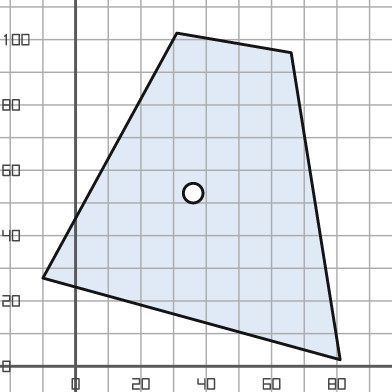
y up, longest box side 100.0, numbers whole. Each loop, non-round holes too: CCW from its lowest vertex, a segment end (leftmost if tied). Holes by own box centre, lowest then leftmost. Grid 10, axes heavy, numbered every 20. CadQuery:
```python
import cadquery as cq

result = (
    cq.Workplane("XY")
    .moveTo(81.0, 2.0)
    .lineTo(66.0, 96.0)
    .lineTo(31.0, 102.0)
    .lineTo(-10.0, 27.0)
    .close()
    .moveTo(36.0, 53.0)
    .circle(3.0)
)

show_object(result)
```